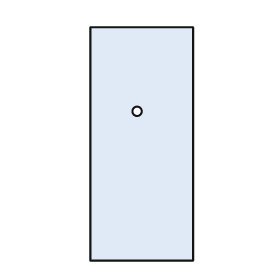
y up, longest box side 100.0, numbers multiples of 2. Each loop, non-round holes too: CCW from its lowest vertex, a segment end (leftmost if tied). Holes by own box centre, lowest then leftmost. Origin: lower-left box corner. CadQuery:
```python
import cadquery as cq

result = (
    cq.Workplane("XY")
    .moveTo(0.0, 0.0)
    .lineTo(44.0, 0.0)
    .lineTo(44.0, 100.0)
    .lineTo(0.0, 100.0)
    .close()
    .moveTo(20.0, 64.0)
    .circle(2.0)
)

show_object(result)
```